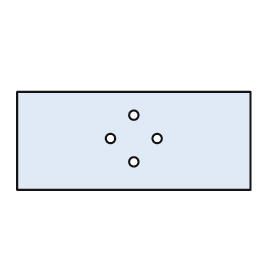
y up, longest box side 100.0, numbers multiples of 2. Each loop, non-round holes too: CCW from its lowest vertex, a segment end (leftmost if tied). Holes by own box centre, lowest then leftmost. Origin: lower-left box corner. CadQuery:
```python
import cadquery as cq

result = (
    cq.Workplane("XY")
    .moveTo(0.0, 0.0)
    .lineTo(100.0, 0.0)
    .lineTo(100.0, 42.0)
    .lineTo(0.0, 42.0)
    .close()
    .moveTo(50.0, 12.0)
    .circle(2.0)
    .moveTo(40.0, 22.0)
    .circle(2.0)
    .moveTo(60.0, 22.0)
    .circle(2.0)
    .moveTo(50.0, 32.0)
    .circle(2.0)
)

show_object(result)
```